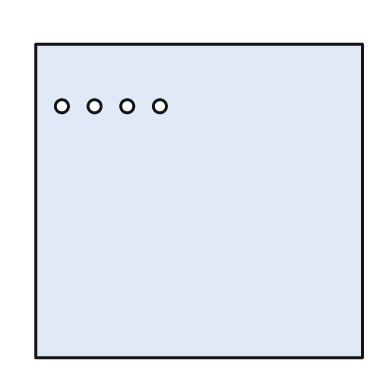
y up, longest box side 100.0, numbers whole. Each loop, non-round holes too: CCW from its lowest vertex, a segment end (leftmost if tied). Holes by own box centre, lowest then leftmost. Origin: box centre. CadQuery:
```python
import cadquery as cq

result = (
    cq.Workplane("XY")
    .moveTo(-50.0, -48.0)
    .lineTo(50.0, -48.0)
    .lineTo(50.0, 48.0)
    .lineTo(-50.0, 48.0)
    .close()
    .moveTo(-42.0, 29.0)
    .circle(2.0)
    .moveTo(-32.0, 29.0)
    .circle(2.0)
    .moveTo(-22.0, 29.0)
    .circle(2.0)
    .moveTo(-12.0, 29.0)
    .circle(2.0)
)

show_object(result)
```